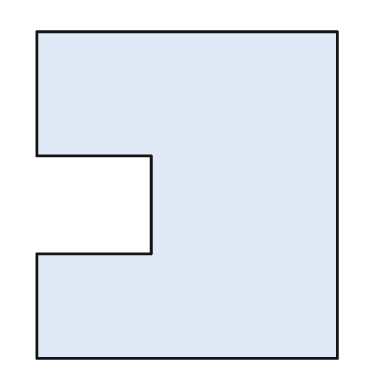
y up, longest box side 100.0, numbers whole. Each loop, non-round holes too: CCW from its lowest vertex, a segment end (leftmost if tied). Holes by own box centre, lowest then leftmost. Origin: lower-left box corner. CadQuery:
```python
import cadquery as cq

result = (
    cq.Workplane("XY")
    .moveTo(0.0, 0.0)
    .lineTo(92.0, 0.0)
    .lineTo(92.0, 100.0)
    .lineTo(0.0, 100.0)
    .lineTo(0.0, 62.0)
    .lineTo(35.0, 62.0)
    .lineTo(35.0, 32.0)
    .lineTo(0.0, 32.0)
    .close()
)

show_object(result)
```